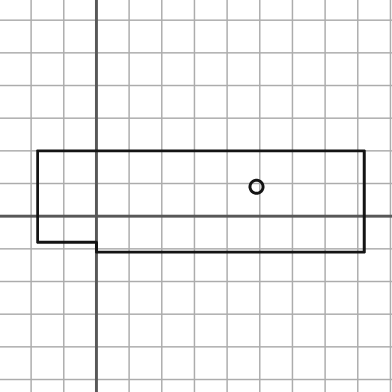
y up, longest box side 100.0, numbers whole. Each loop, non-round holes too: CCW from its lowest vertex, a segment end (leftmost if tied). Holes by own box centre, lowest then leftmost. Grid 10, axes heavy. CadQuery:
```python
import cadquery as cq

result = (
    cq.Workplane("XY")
    .moveTo(0.0, -11.0)
    .lineTo(82.0, -11.0)
    .lineTo(82.0, 20.0)
    .lineTo(-18.0, 20.0)
    .lineTo(-18.0, -8.0)
    .lineTo(0.0, -8.0)
    .close()
    .moveTo(49.0, 9.0)
    .circle(2.0)
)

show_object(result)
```